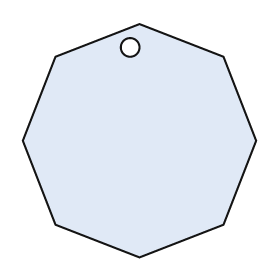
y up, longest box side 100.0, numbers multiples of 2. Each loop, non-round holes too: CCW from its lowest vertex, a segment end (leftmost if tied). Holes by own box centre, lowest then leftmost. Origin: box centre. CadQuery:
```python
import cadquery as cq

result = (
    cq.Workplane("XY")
    .moveTo(0.0, -50.0)
    .lineTo(36.0, -36.0)
    .lineTo(50.0, 0.0)
    .lineTo(36.0, 36.0)
    .lineTo(0.0, 50.0)
    .lineTo(-36.0, 36.0)
    .lineTo(-50.0, 0.0)
    .lineTo(-36.0, -36.0)
    .close()
    .moveTo(-4.0, 40.0)
    .circle(4.0)
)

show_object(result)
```